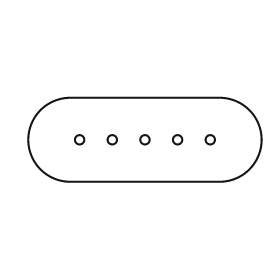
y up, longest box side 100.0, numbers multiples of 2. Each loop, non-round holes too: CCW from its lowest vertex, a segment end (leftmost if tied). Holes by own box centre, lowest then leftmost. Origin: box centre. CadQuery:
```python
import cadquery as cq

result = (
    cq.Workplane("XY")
    .moveTo(-32.0, -18.0)
    .lineTo(32.0, -18.0)
    .threePointArc((50.0, 0.0), (32.0, 18.0))
    .lineTo(-32.0, 18.0)
    .threePointArc((-50.0, 0.0), (-32.0, -18.0))
    .close()
    .moveTo(-28.0, 0.0)
    .circle(2.0)
    .moveTo(-14.0, 0.0)
    .circle(2.0)
    .moveTo(0.0, 0.0)
    .circle(2.0)
    .moveTo(14.0, 0.0)
    .circle(2.0)
    .moveTo(28.0, 0.0)
    .circle(2.0)
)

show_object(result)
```